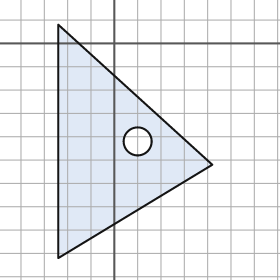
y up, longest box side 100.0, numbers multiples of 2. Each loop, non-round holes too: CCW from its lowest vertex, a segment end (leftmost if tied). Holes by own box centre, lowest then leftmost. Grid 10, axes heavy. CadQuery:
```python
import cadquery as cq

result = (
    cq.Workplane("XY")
    .moveTo(-24.0, -92.0)
    .lineTo(42.0, -52.0)
    .lineTo(-24.0, 8.0)
    .close()
    .moveTo(10.0, -42.0)
    .circle(6.0)
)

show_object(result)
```